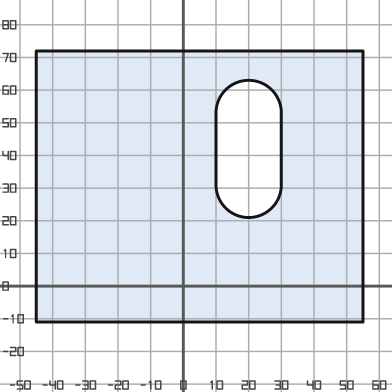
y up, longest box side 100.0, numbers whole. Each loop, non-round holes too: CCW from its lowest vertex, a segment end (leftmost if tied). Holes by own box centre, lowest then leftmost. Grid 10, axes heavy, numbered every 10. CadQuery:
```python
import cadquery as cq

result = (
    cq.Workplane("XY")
    .moveTo(-45.0, -11.0)
    .lineTo(55.0, -11.0)
    .lineTo(55.0, 72.0)
    .lineTo(-45.0, 72.0)
    .close()
    .moveTo(10.0, 31.0)
    .threePointArc((20.0, 21.0), (30.0, 31.0))
    .lineTo(30.0, 53.0)
    .threePointArc((20.0, 63.0), (10.0, 53.0))
    .close()
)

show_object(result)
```